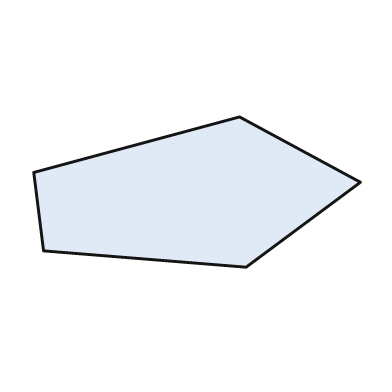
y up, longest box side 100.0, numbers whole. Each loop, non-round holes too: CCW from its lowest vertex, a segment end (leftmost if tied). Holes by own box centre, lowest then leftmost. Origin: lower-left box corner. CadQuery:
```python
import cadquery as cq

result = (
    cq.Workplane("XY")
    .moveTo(65.0, 0.0)
    .lineTo(100.0, 26.0)
    .lineTo(63.0, 46.0)
    .lineTo(0.0, 29.0)
    .lineTo(3.0, 5.0)
    .close()
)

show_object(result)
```